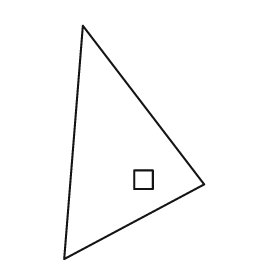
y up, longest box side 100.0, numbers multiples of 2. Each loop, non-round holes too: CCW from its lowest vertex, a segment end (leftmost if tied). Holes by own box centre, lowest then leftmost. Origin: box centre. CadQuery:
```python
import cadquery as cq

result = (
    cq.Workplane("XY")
    .moveTo(-30.0, -50.0)
    .lineTo(30.0, -18.0)
    .lineTo(-22.0, 50.0)
    .close()
    .moveTo(0.0, -20.0)
    .lineTo(8.0, -20.0)
    .lineTo(8.0, -12.0)
    .lineTo(0.0, -12.0)
    .close()
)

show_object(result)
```